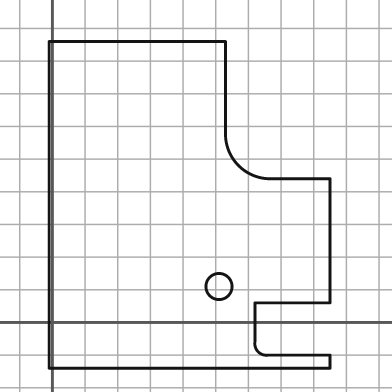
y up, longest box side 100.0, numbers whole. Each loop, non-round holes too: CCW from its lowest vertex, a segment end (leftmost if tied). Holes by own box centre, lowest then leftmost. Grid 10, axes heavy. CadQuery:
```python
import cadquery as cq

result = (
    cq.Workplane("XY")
    .moveTo(-1.0, -14.0)
    .lineTo(85.0, -14.0)
    .lineTo(85.0, -10.0)
    .lineTo(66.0, -10.0)
    .threePointArc((63.0, -9.0), (62.0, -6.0))
    .lineTo(62.0, 6.0)
    .lineTo(85.0, 6.0)
    .lineTo(85.0, 44.0)
    .lineTo(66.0, 44.0)
    .threePointArc((57.0, 48.0), (53.0, 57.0))
    .lineTo(53.0, 86.0)
    .lineTo(-1.0, 86.0)
    .close()
    .moveTo(51.0, 11.0)
    .circle(4.0)
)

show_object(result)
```